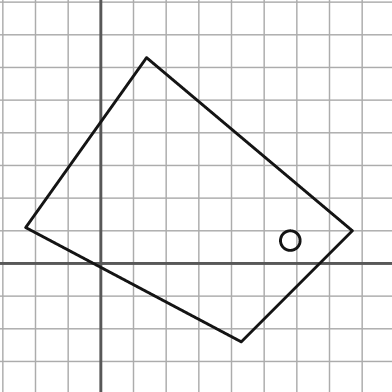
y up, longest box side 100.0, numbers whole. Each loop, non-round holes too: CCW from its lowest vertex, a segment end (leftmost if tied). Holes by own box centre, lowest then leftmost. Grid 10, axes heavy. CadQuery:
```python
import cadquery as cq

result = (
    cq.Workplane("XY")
    .moveTo(43.0, -24.0)
    .lineTo(77.0, 10.0)
    .lineTo(14.0, 63.0)
    .lineTo(-23.0, 11.0)
    .close()
    .moveTo(58.0, 7.0)
    .circle(3.0)
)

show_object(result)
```